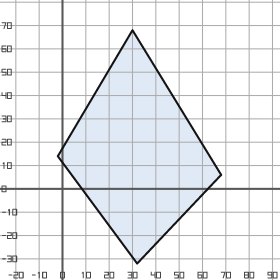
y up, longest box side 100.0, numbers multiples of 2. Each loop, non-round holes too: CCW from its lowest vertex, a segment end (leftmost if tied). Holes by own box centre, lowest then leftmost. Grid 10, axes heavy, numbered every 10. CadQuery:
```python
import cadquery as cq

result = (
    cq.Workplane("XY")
    .moveTo(32.0, -32.0)
    .lineTo(68.0, 6.0)
    .lineTo(30.0, 68.0)
    .lineTo(-2.0, 14.0)
    .close()
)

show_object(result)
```